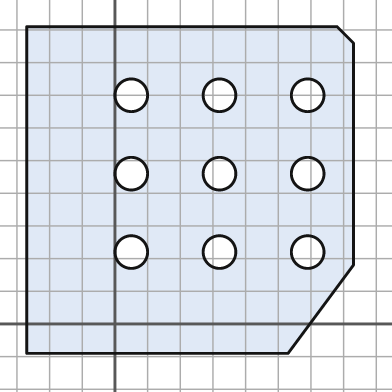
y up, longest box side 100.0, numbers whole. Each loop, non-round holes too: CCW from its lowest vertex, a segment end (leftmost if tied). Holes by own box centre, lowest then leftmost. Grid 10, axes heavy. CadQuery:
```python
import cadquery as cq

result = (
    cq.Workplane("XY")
    .moveTo(-27.0, -9.0)
    .lineTo(53.0, -9.0)
    .lineTo(73.0, 18.0)
    .lineTo(73.0, 86.0)
    .lineTo(68.0, 91.0)
    .lineTo(-27.0, 91.0)
    .close()
    .moveTo(5.0, 22.0)
    .circle(5.0)
    .moveTo(32.0, 22.0)
    .circle(5.0)
    .moveTo(59.0, 22.0)
    .circle(5.0)
    .moveTo(5.0, 46.0)
    .circle(5.0)
    .moveTo(32.0, 46.0)
    .circle(5.0)
    .moveTo(59.0, 46.0)
    .circle(5.0)
    .moveTo(5.0, 70.0)
    .circle(5.0)
    .moveTo(32.0, 70.0)
    .circle(5.0)
    .moveTo(59.0, 70.0)
    .circle(5.0)
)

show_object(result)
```